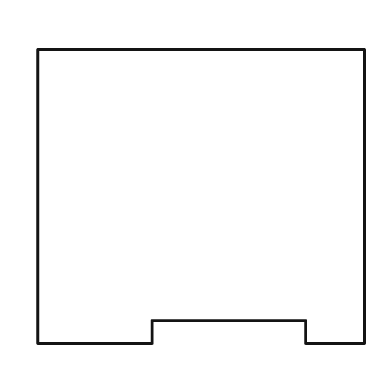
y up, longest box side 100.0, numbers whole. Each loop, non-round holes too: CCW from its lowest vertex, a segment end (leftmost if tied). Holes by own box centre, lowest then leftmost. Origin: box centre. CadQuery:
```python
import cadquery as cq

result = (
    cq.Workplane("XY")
    .moveTo(-50.0, -45.0)
    .lineTo(-15.0, -45.0)
    .lineTo(-15.0, -38.0)
    .lineTo(32.0, -38.0)
    .lineTo(32.0, -45.0)
    .lineTo(50.0, -45.0)
    .lineTo(50.0, 45.0)
    .lineTo(-50.0, 45.0)
    .close()
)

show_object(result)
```